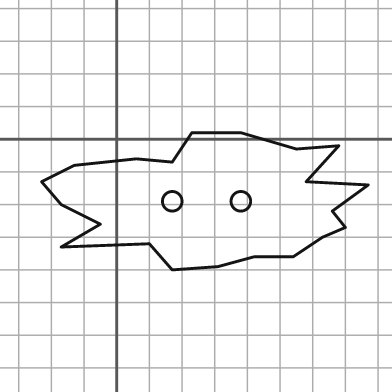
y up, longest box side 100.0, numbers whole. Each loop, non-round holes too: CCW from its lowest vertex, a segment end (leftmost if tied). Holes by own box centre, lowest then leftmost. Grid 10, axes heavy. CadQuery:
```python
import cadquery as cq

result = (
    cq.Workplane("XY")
    .moveTo(17.0, -40.0)
    .lineTo(31.0, -39.0)
    .lineTo(42.0, -36.0)
    .lineTo(54.0, -36.0)
    .lineTo(63.0, -30.0)
    .lineTo(70.0, -27.0)
    .lineTo(66.0, -22.0)
    .lineTo(77.0, -14.0)
    .lineTo(58.0, -13.0)
    .lineTo(68.0, -2.0)
    .lineTo(55.0, -3.0)
    .lineTo(38.0, 2.0)
    .lineTo(23.0, 2.0)
    .lineTo(17.0, -7.0)
    .lineTo(6.0, -6.0)
    .lineTo(-13.0, -8.0)
    .lineTo(-23.0, -13.0)
    .lineTo(-17.0, -20.0)
    .lineTo(-5.0, -26.0)
    .lineTo(-17.0, -33.0)
    .lineTo(10.0, -32.0)
    .close()
    .moveTo(17.0, -19.0)
    .circle(3.0)
    .moveTo(38.0, -19.0)
    .circle(3.0)
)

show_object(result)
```